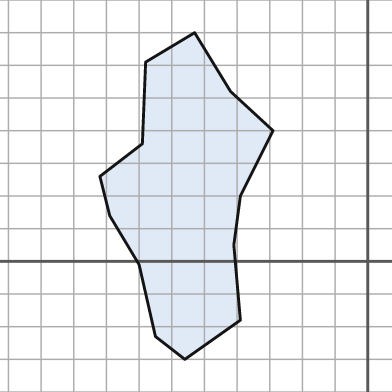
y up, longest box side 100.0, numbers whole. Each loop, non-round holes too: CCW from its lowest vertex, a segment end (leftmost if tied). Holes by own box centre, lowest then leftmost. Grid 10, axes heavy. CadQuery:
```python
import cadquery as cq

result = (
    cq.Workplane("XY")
    .moveTo(-56.0, -30.0)
    .lineTo(-39.0, -18.0)
    .lineTo(-41.0, 5.0)
    .lineTo(-39.0, 20.0)
    .lineTo(-29.0, 40.0)
    .lineTo(-42.0, 52.0)
    .lineTo(-53.0, 70.0)
    .lineTo(-68.0, 61.0)
    .lineTo(-69.0, 36.0)
    .lineTo(-82.0, 26.0)
    .lineTo(-79.0, 14.0)
    .lineTo(-70.0, -1.0)
    .lineTo(-65.0, -23.0)
    .close()
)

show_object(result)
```